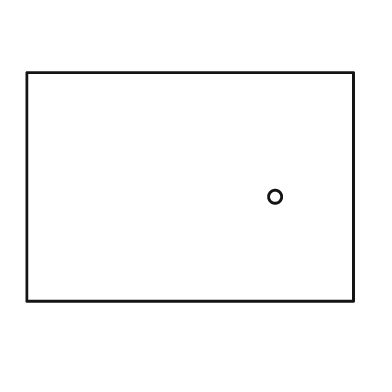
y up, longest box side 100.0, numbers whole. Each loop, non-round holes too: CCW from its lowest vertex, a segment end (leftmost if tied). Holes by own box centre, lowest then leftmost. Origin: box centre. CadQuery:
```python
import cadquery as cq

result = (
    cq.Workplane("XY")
    .moveTo(-50.0, -35.0)
    .lineTo(50.0, -35.0)
    .lineTo(50.0, 35.0)
    .lineTo(-50.0, 35.0)
    .close()
    .moveTo(26.0, -3.0)
    .circle(2.0)
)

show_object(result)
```